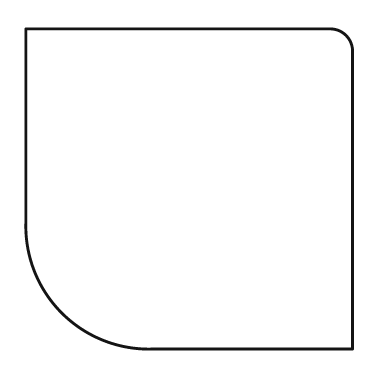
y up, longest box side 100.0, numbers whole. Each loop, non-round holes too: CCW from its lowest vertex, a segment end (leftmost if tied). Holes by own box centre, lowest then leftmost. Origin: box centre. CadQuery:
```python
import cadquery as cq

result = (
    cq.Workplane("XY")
    .moveTo(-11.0, -49.0)
    .lineTo(50.0, -49.0)
    .lineTo(50.0, 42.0)
    .threePointArc((48.0, 47.0), (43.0, 49.0))
    .lineTo(-50.0, 49.0)
    .lineTo(-50.0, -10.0)
    .threePointArc((-39.0, -38.0), (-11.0, -49.0))
    .close()
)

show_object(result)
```